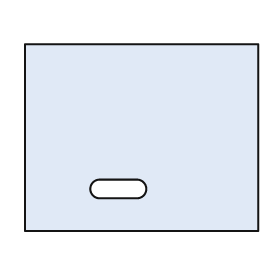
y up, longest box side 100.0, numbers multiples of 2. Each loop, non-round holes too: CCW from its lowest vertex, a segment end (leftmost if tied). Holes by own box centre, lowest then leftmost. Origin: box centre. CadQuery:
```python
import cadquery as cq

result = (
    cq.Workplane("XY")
    .moveTo(-50.0, -40.0)
    .lineTo(50.0, -40.0)
    .lineTo(50.0, 40.0)
    .lineTo(-50.0, 40.0)
    .close()
    .moveTo(-18.0, -26.0)
    .lineTo(-2.0, -26.0)
    .threePointArc((2.0, -22.0), (-2.0, -18.0))
    .lineTo(-18.0, -18.0)
    .threePointArc((-22.0, -22.0), (-18.0, -26.0))
    .close()
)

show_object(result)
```